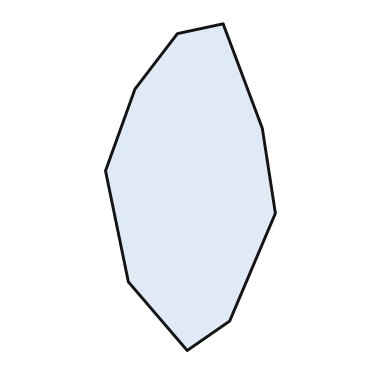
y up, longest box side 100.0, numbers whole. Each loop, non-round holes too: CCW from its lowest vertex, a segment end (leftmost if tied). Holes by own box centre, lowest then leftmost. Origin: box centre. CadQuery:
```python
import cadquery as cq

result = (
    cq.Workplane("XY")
    .moveTo(-1.0, -50.0)
    .lineTo(12.0, -41.0)
    .lineTo(26.0, -8.0)
    .lineTo(22.0, 18.0)
    .lineTo(10.0, 50.0)
    .lineTo(-4.0, 47.0)
    .lineTo(-17.0, 30.0)
    .lineTo(-26.0, 5.0)
    .lineTo(-19.0, -29.0)
    .close()
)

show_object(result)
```